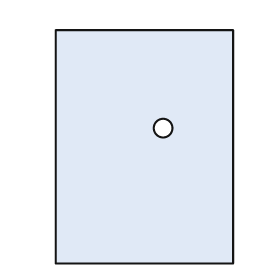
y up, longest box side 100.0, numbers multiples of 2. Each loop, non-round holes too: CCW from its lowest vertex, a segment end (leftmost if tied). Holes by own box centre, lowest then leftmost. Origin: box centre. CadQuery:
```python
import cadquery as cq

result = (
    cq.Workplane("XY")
    .moveTo(-38.0, -50.0)
    .lineTo(38.0, -50.0)
    .lineTo(38.0, 50.0)
    .lineTo(-38.0, 50.0)
    .close()
    .moveTo(8.0, 8.0)
    .circle(4.0)
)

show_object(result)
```